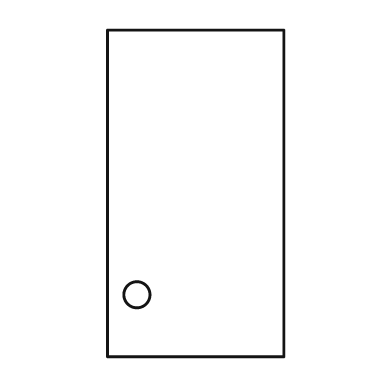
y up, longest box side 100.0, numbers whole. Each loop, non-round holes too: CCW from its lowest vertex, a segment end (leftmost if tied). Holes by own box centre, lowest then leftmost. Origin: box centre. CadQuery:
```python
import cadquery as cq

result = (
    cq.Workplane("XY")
    .moveTo(-27.0, -50.0)
    .lineTo(27.0, -50.0)
    .lineTo(27.0, 50.0)
    .lineTo(-27.0, 50.0)
    .close()
    .moveTo(-18.0, -31.0)
    .circle(4.0)
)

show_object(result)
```